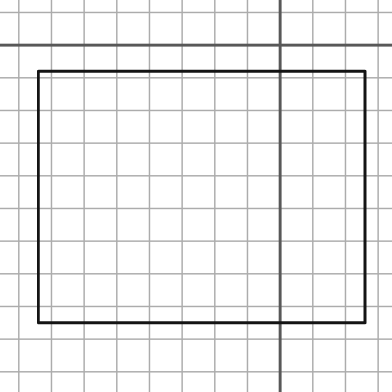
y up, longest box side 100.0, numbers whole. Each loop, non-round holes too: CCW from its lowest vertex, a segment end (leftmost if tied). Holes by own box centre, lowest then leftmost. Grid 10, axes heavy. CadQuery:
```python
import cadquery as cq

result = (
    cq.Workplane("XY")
    .moveTo(-74.0, -85.0)
    .lineTo(26.0, -85.0)
    .lineTo(26.0, -8.0)
    .lineTo(-74.0, -8.0)
    .close()
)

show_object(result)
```